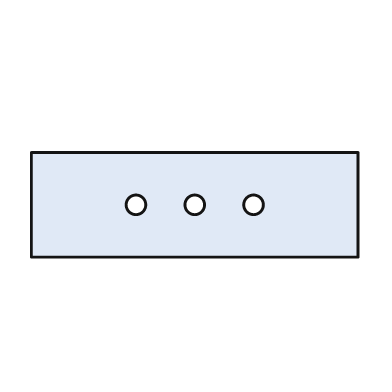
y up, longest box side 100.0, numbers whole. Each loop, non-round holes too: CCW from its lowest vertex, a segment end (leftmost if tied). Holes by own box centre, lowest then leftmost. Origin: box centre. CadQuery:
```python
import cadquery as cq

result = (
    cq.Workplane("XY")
    .moveTo(-50.0, -16.0)
    .lineTo(50.0, -16.0)
    .lineTo(50.0, 16.0)
    .lineTo(-50.0, 16.0)
    .close()
    .moveTo(-18.0, 0.0)
    .circle(3.0)
    .moveTo(0.0, 0.0)
    .circle(3.0)
    .moveTo(18.0, 0.0)
    .circle(3.0)
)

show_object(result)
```